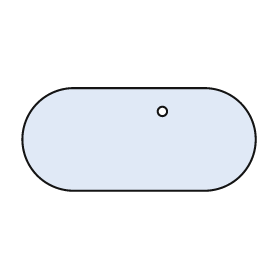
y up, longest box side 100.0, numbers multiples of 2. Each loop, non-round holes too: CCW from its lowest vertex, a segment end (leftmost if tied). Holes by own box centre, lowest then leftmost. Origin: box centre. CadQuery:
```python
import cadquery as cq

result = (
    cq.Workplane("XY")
    .moveTo(-28.0, -22.0)
    .lineTo(28.0, -22.0)
    .threePointArc((50.0, 0.0), (28.0, 22.0))
    .lineTo(-28.0, 22.0)
    .threePointArc((-50.0, 0.0), (-28.0, -22.0))
    .close()
    .moveTo(10.0, 12.0)
    .circle(2.0)
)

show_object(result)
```